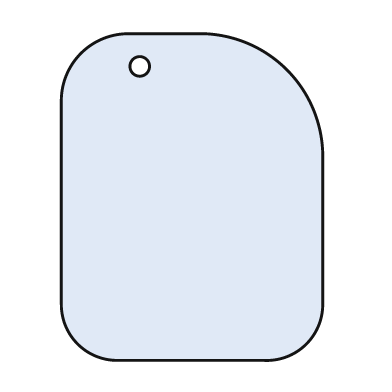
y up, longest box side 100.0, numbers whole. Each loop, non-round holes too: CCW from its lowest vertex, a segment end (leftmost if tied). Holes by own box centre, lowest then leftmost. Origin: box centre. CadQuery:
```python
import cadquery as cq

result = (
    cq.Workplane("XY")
    .moveTo(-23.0, -50.0)
    .lineTo(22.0, -50.0)
    .threePointArc((35.0, -45.0), (40.0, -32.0))
    .lineTo(40.0, 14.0)
    .threePointArc((29.0, 39.0), (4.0, 50.0))
    .lineTo(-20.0, 50.0)
    .threePointArc((-34.0, 44.0), (-40.0, 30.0))
    .lineTo(-40.0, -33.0)
    .threePointArc((-35.0, -45.0), (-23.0, -50.0))
    .close()
    .moveTo(-16.0, 40.0)
    .circle(3.0)
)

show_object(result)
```